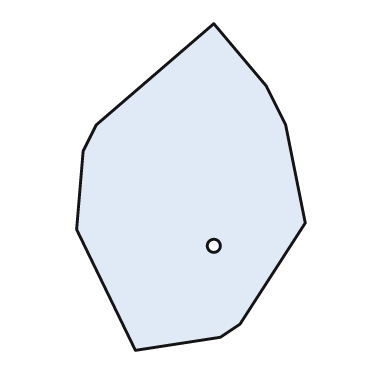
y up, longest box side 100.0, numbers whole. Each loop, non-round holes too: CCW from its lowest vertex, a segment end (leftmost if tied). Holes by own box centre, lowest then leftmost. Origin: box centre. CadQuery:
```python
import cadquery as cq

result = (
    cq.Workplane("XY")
    .moveTo(-17.0, -50.0)
    .lineTo(9.0, -46.0)
    .lineTo(15.0, -42.0)
    .lineTo(35.0, -11.0)
    .lineTo(29.0, 19.0)
    .lineTo(23.0, 31.0)
    .lineTo(7.0, 50.0)
    .lineTo(-29.0, 19.0)
    .lineTo(-33.0, 11.0)
    .lineTo(-35.0, -13.0)
    .close()
    .moveTo(7.0, -18.0)
    .circle(2.0)
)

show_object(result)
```